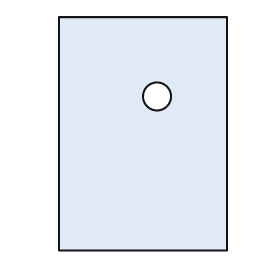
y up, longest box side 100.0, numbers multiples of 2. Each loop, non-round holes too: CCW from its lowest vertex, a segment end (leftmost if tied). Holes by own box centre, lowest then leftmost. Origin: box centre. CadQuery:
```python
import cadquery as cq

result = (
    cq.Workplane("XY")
    .moveTo(-36.0, -50.0)
    .lineTo(36.0, -50.0)
    .lineTo(36.0, 50.0)
    .lineTo(-36.0, 50.0)
    .close()
    .moveTo(6.0, 16.0)
    .circle(6.0)
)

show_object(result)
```